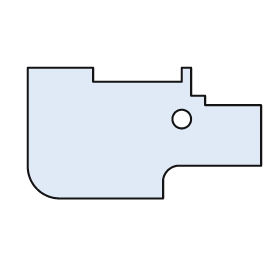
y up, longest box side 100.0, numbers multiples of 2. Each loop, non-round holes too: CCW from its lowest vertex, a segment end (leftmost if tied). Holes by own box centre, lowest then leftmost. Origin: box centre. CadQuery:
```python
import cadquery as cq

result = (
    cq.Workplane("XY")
    .moveTo(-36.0, -28.0)
    .lineTo(8.0, -28.0)
    .lineTo(8.0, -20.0)
    .threePointArc((10.0, -16.0), (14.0, -14.0))
    .lineTo(50.0, -14.0)
    .lineTo(50.0, 12.0)
    .lineTo(26.0, 12.0)
    .lineTo(26.0, 16.0)
    .lineTo(20.0, 16.0)
    .lineTo(20.0, 28.0)
    .lineTo(16.0, 28.0)
    .lineTo(16.0, 22.0)
    .lineTo(-22.0, 22.0)
    .lineTo(-22.0, 28.0)
    .lineTo(-50.0, 28.0)
    .lineTo(-50.0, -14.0)
    .threePointArc((-46.0, -24.0), (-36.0, -28.0))
    .close()
    .moveTo(16.0, 6.0)
    .circle(4.0)
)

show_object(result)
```